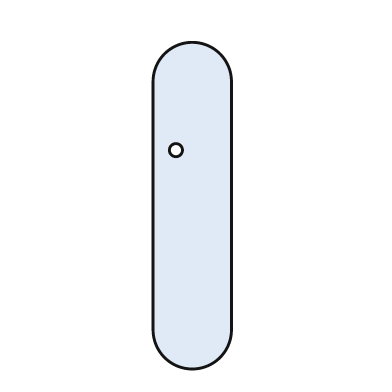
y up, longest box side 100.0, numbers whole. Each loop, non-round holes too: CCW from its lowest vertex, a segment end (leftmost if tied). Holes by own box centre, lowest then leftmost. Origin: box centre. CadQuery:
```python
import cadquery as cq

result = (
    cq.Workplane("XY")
    .moveTo(-12.0, -38.0)
    .threePointArc((0.0, -50.0), (12.0, -38.0))
    .lineTo(12.0, 38.0)
    .threePointArc((0.0, 50.0), (-12.0, 38.0))
    .close()
    .moveTo(-5.0, 17.0)
    .circle(2.0)
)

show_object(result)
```